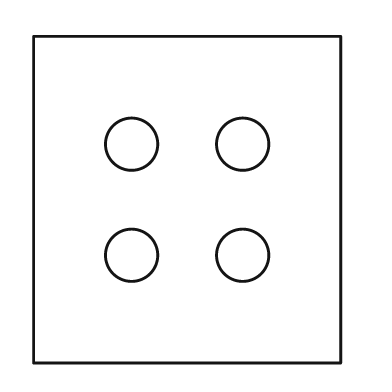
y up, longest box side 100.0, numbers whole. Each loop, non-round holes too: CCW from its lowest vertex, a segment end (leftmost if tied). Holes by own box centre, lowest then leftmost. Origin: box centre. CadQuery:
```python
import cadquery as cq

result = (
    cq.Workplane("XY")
    .moveTo(-47.0, -50.0)
    .lineTo(47.0, -50.0)
    .lineTo(47.0, 50.0)
    .lineTo(-47.0, 50.0)
    .close()
    .moveTo(-17.0, -17.0)
    .circle(8.0)
    .moveTo(17.0, -17.0)
    .circle(8.0)
    .moveTo(-17.0, 17.0)
    .circle(8.0)
    .moveTo(17.0, 17.0)
    .circle(8.0)
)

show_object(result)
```